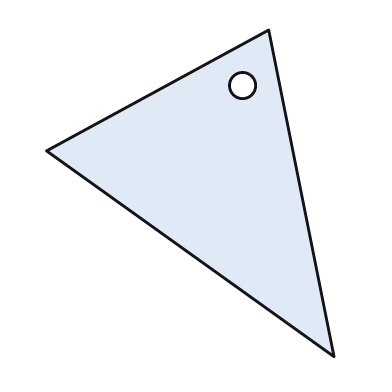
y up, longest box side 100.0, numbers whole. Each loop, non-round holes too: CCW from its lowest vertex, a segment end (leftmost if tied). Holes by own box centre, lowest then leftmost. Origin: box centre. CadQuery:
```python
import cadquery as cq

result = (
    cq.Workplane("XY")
    .moveTo(44.0, -50.0)
    .lineTo(24.0, 50.0)
    .lineTo(-44.0, 13.0)
    .close()
    .moveTo(16.0, 33.0)
    .circle(4.0)
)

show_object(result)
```